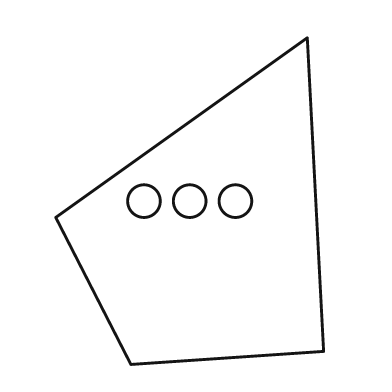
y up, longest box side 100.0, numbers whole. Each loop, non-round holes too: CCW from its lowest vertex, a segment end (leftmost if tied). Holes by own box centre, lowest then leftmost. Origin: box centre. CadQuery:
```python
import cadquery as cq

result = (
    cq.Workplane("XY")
    .moveTo(-18.0, -50.0)
    .lineTo(41.0, -46.0)
    .lineTo(36.0, 50.0)
    .lineTo(-41.0, -5.0)
    .close()
    .moveTo(-14.0, 0.0)
    .circle(5.0)
    .moveTo(0.0, 0.0)
    .circle(5.0)
    .moveTo(14.0, 0.0)
    .circle(5.0)
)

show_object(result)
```